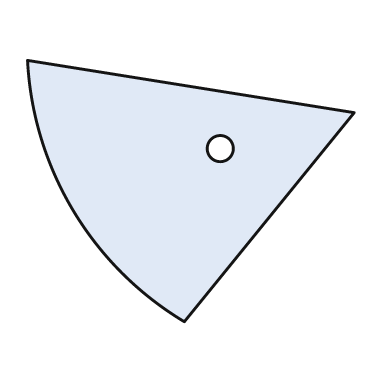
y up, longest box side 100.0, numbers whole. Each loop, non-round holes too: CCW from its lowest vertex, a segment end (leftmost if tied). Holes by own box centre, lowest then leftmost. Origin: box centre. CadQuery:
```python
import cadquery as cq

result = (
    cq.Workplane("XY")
    .moveTo(-2.0, -40.0)
    .lineTo(50.0, 24.0)
    .lineTo(-50.0, 40.0)
    .threePointArc((-36.0, -6.0), (-2.0, -40.0))
    .close()
    .moveTo(9.0, 13.0)
    .circle(4.0)
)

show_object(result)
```